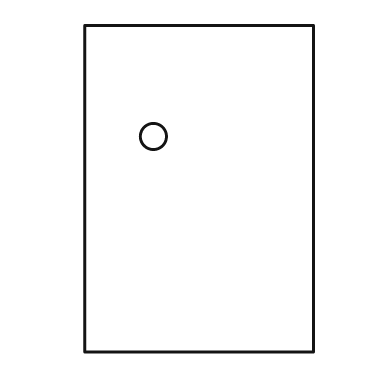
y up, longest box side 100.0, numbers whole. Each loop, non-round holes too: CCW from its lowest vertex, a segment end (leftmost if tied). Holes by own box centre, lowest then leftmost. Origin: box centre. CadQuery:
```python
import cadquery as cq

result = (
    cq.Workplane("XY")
    .moveTo(-35.0, -50.0)
    .lineTo(35.0, -50.0)
    .lineTo(35.0, 50.0)
    .lineTo(-35.0, 50.0)
    .close()
    .moveTo(-14.0, 16.0)
    .circle(4.0)
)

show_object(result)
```